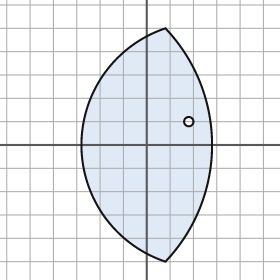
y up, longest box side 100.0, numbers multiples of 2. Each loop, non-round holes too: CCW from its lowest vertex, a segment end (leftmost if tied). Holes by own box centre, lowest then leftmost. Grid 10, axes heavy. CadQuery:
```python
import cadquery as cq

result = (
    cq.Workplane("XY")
    .moveTo(8.0, -50.0)
    .threePointArc((28.0, 0.0), (8.0, 50.0))
    .threePointArc((-28.0, 0.0), (8.0, -50.0))
    .close()
    .moveTo(18.0, 10.0)
    .circle(2.0)
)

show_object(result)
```